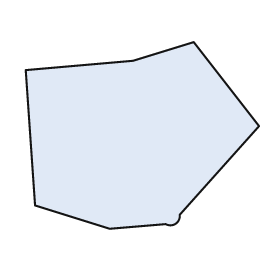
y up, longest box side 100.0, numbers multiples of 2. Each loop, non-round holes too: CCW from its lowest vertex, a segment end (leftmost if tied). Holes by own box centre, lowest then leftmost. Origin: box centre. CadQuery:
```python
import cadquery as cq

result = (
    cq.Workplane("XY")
    .moveTo(-14.0, -40.0)
    .lineTo(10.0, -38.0)
    .threePointArc((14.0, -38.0), (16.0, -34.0))
    .lineTo(50.0, 4.0)
    .lineTo(22.0, 40.0)
    .lineTo(-4.0, 32.0)
    .lineTo(-50.0, 28.0)
    .lineTo(-46.0, -30.0)
    .close()
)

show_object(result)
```